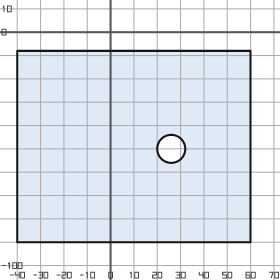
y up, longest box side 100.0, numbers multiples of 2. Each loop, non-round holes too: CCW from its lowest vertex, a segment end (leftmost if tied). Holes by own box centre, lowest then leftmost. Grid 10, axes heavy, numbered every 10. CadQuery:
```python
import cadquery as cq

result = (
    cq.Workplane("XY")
    .moveTo(-40.0, -90.0)
    .lineTo(60.0, -90.0)
    .lineTo(60.0, -8.0)
    .lineTo(-40.0, -8.0)
    .close()
    .moveTo(26.0, -50.0)
    .circle(6.0)
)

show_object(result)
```